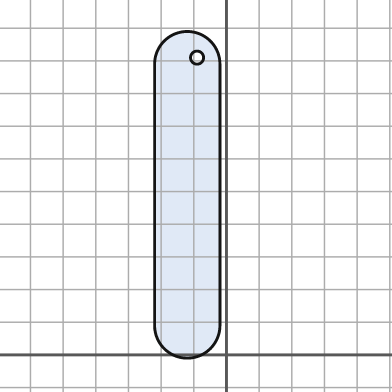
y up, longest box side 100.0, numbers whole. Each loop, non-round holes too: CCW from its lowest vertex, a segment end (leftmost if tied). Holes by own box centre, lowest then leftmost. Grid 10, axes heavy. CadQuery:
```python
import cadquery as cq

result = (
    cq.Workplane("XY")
    .moveTo(-22.0, 9.0)
    .threePointArc((-12.0, -1.0), (-2.0, 9.0))
    .lineTo(-2.0, 89.0)
    .threePointArc((-12.0, 99.0), (-22.0, 89.0))
    .close()
    .moveTo(-9.0, 91.0)
    .circle(2.0)
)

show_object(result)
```